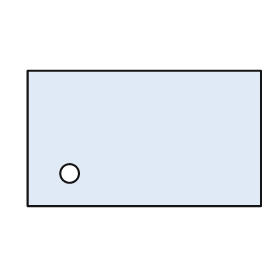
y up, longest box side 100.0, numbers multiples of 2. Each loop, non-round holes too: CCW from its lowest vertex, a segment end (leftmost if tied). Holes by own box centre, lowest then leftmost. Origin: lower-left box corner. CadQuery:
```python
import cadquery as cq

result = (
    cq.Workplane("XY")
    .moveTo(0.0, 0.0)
    .lineTo(100.0, 0.0)
    .lineTo(100.0, 58.0)
    .lineTo(0.0, 58.0)
    .close()
    .moveTo(18.0, 14.0)
    .circle(4.0)
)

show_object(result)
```